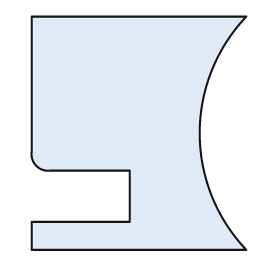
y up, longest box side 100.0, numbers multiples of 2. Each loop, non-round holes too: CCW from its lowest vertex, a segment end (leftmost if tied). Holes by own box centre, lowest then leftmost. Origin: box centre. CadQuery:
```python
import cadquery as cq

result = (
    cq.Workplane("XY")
    .moveTo(-46.0, -50.0)
    .lineTo(46.0, -50.0)
    .threePointArc((26.0, 0.0), (46.0, 50.0))
    .lineTo(-46.0, 50.0)
    .lineTo(-46.0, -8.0)
    .threePointArc((-44.0, -14.0), (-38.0, -16.0))
    .lineTo(-4.0, -16.0)
    .lineTo(-4.0, -38.0)
    .lineTo(-46.0, -38.0)
    .close()
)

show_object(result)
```